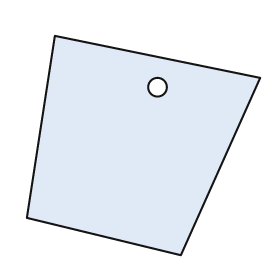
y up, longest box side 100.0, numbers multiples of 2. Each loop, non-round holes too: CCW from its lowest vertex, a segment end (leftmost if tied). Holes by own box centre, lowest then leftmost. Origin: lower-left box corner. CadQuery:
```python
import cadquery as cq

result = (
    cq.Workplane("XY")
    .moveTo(66.0, 0.0)
    .lineTo(100.0, 76.0)
    .lineTo(12.0, 94.0)
    .lineTo(0.0, 16.0)
    .close()
    .moveTo(56.0, 72.0)
    .circle(4.0)
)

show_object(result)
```